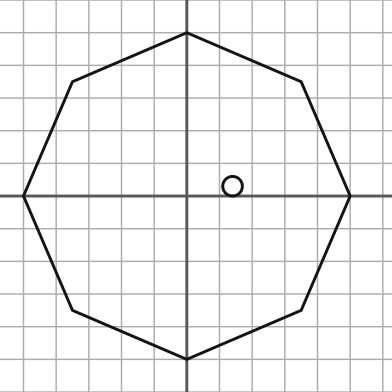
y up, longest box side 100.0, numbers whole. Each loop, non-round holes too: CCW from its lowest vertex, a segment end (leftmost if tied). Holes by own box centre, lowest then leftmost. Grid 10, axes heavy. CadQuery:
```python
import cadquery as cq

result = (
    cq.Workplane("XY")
    .moveTo(0.0, -50.0)
    .lineTo(35.0, -35.0)
    .lineTo(50.0, 0.0)
    .lineTo(35.0, 35.0)
    .lineTo(0.0, 50.0)
    .lineTo(-35.0, 35.0)
    .lineTo(-50.0, 0.0)
    .lineTo(-35.0, -35.0)
    .close()
    .moveTo(14.0, 3.0)
    .circle(3.0)
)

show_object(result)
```